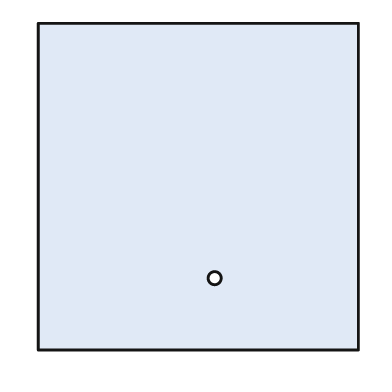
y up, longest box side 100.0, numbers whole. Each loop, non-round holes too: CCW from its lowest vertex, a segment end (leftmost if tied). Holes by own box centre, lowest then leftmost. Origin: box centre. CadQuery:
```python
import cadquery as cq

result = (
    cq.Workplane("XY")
    .moveTo(-49.0, -50.0)
    .lineTo(49.0, -50.0)
    .lineTo(49.0, 50.0)
    .lineTo(-49.0, 50.0)
    .close()
    .moveTo(5.0, -28.0)
    .circle(2.0)
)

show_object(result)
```